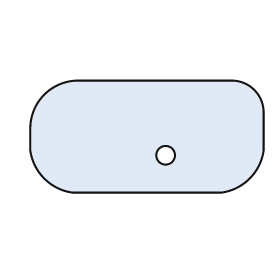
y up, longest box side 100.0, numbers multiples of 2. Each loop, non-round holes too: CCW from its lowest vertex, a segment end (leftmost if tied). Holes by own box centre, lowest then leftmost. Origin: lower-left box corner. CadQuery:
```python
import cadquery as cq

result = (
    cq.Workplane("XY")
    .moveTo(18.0, 0.0)
    .lineTo(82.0, 0.0)
    .threePointArc((94.0, 6.0), (100.0, 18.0))
    .lineTo(100.0, 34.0)
    .threePointArc((96.0, 44.0), (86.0, 48.0))
    .lineTo(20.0, 48.0)
    .threePointArc((6.0, 42.0), (0.0, 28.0))
    .lineTo(0.0, 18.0)
    .threePointArc((6.0, 6.0), (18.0, 0.0))
    .close()
    .moveTo(58.0, 16.0)
    .circle(4.0)
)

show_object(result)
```